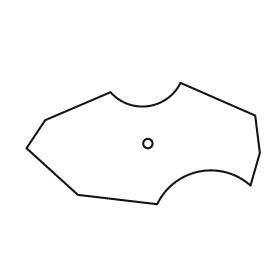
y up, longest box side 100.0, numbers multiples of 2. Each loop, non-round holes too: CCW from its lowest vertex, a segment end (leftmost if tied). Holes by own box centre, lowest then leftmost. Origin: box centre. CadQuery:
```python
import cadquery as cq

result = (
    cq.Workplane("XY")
    .moveTo(6.0, -26.0)
    .threePointArc((24.0, -12.0), (46.0, -18.0))
    .lineTo(50.0, -4.0)
    .lineTo(48.0, 12.0)
    .lineTo(16.0, 26.0)
    .threePointArc((2.0, 16.0), (-14.0, 22.0))
    .lineTo(-42.0, 10.0)
    .lineTo(-50.0, -2.0)
    .lineTo(-28.0, -22.0)
    .close()
    .moveTo(2.0, 0.0)
    .circle(2.0)
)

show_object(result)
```